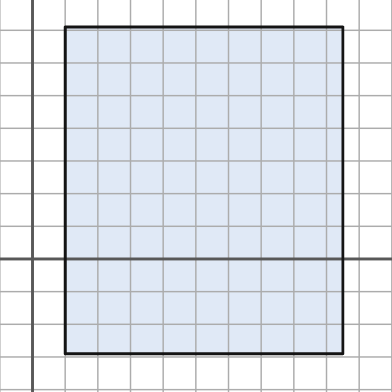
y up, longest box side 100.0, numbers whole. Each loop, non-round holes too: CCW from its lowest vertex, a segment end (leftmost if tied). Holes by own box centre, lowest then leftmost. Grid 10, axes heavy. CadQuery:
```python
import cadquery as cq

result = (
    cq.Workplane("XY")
    .moveTo(10.0, -29.0)
    .lineTo(95.0, -29.0)
    .lineTo(95.0, 71.0)
    .lineTo(10.0, 71.0)
    .close()
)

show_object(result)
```